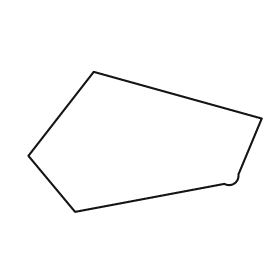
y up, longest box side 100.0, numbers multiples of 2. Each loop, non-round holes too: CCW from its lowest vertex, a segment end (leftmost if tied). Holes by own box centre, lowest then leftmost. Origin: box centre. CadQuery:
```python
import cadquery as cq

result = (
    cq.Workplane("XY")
    .moveTo(-30.0, -30.0)
    .lineTo(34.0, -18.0)
    .threePointArc((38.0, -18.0), (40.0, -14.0))
    .lineTo(50.0, 10.0)
    .lineTo(-22.0, 30.0)
    .lineTo(-50.0, -6.0)
    .close()
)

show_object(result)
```